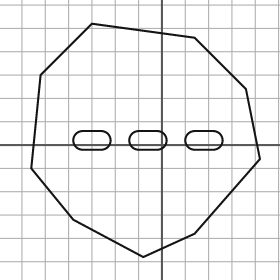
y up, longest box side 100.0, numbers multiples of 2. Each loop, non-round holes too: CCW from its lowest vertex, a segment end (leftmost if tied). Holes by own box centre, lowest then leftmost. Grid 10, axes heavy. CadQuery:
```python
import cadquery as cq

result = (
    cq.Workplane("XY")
    .moveTo(-8.0, -48.0)
    .lineTo(14.0, -38.0)
    .lineTo(42.0, -6.0)
    .lineTo(36.0, 24.0)
    .lineTo(14.0, 46.0)
    .lineTo(-30.0, 52.0)
    .lineTo(-52.0, 30.0)
    .lineTo(-56.0, -10.0)
    .lineTo(-38.0, -32.0)
    .close()
    .moveTo(-34.0, -2.0)
    .lineTo(-26.0, -2.0)
    .threePointArc((-22.0, 2.0), (-26.0, 6.0))
    .lineTo(-34.0, 6.0)
    .threePointArc((-38.0, 2.0), (-34.0, -2.0))
    .close()
    .moveTo(-10.0, -2.0)
    .lineTo(-2.0, -2.0)
    .threePointArc((2.0, 2.0), (-2.0, 6.0))
    .lineTo(-10.0, 6.0)
    .threePointArc((-14.0, 2.0), (-10.0, -2.0))
    .close()
    .moveTo(14.0, -2.0)
    .lineTo(22.0, -2.0)
    .threePointArc((26.0, 2.0), (22.0, 6.0))
    .lineTo(14.0, 6.0)
    .threePointArc((10.0, 2.0), (14.0, -2.0))
    .close()
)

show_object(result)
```